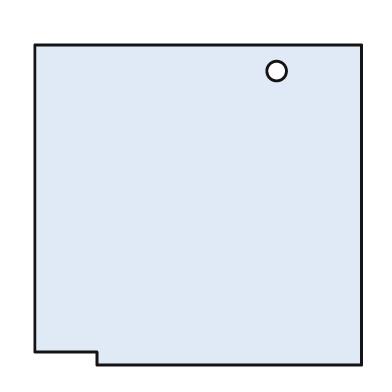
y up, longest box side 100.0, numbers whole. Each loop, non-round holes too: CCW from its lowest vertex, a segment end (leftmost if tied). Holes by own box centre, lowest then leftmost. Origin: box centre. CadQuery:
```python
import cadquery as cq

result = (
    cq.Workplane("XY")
    .moveTo(-31.0, -49.0)
    .lineTo(50.0, -49.0)
    .lineTo(50.0, 49.0)
    .lineTo(-50.0, 49.0)
    .lineTo(-50.0, -45.0)
    .lineTo(-31.0, -45.0)
    .close()
    .moveTo(24.0, 41.0)
    .circle(3.0)
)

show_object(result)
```